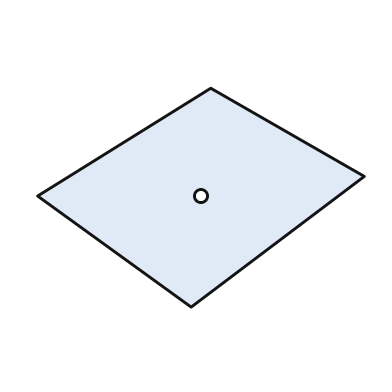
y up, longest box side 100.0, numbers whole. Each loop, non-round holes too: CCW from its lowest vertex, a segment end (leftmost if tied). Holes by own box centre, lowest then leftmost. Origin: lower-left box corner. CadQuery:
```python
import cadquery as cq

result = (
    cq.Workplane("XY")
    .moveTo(47.0, 0.0)
    .lineTo(100.0, 40.0)
    .lineTo(53.0, 67.0)
    .lineTo(0.0, 34.0)
    .close()
    .moveTo(50.0, 34.0)
    .circle(2.0)
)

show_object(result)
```